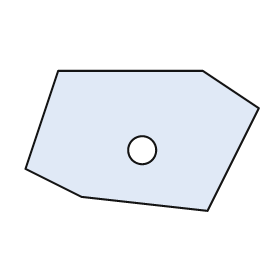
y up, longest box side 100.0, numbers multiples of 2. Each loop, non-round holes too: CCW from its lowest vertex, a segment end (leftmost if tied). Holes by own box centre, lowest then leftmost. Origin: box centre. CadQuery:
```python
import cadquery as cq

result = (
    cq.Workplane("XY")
    .moveTo(28.0, -30.0)
    .lineTo(50.0, 14.0)
    .lineTo(26.0, 30.0)
    .lineTo(-36.0, 30.0)
    .lineTo(-50.0, -12.0)
    .lineTo(-26.0, -24.0)
    .close()
    .moveTo(0.0, -4.0)
    .circle(6.0)
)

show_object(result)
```